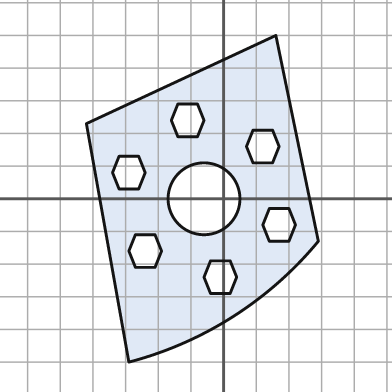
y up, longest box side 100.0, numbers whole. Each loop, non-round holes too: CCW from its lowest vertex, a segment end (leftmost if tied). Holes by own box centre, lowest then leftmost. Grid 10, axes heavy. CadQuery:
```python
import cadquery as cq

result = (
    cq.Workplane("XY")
    .moveTo(-29.0, -50.0)
    .threePointArc((3.0, -36.0), (29.0, -13.0))
    .lineTo(16.0, 50.0)
    .lineTo(-42.0, 23.0)
    .close()
    .moveTo(-4.0, -29.0)
    .lineTo(2.0, -29.0)
    .lineTo(4.0, -24.0)
    .lineTo(2.0, -19.0)
    .lineTo(-4.0, -19.0)
    .lineTo(-6.0, -24.0)
    .close()
    .moveTo(-27.0, -21.0)
    .lineTo(-21.0, -21.0)
    .lineTo(-19.0, -16.0)
    .lineTo(-21.0, -11.0)
    .lineTo(-27.0, -11.0)
    .lineTo(-29.0, -16.0)
    .close()
    .moveTo(14.0, -13.0)
    .lineTo(20.0, -13.0)
    .lineTo(22.0, -8.0)
    .lineTo(20.0, -3.0)
    .lineTo(14.0, -3.0)
    .lineTo(12.0, -8.0)
    .close()
    .moveTo(-6.0, 0.0)
    .circle(11.0)
    .moveTo(-32.0, 3.0)
    .lineTo(-26.0, 3.0)
    .lineTo(-24.0, 8.0)
    .lineTo(-26.0, 13.0)
    .lineTo(-32.0, 13.0)
    .lineTo(-34.0, 8.0)
    .close()
    .moveTo(9.0, 11.0)
    .lineTo(15.0, 11.0)
    .lineTo(17.0, 16.0)
    .lineTo(15.0, 21.0)
    .lineTo(9.0, 21.0)
    .lineTo(7.0, 16.0)
    .close()
    .moveTo(-14.0, 19.0)
    .lineTo(-8.0, 19.0)
    .lineTo(-6.0, 24.0)
    .lineTo(-8.0, 29.0)
    .lineTo(-14.0, 29.0)
    .lineTo(-16.0, 24.0)
    .close()
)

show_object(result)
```